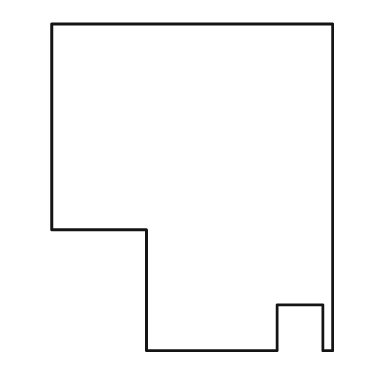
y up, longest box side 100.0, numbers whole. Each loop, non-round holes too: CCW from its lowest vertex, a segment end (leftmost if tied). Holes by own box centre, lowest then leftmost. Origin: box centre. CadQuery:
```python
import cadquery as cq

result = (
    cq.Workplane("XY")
    .moveTo(-14.0, -50.0)
    .lineTo(26.0, -50.0)
    .lineTo(26.0, -36.0)
    .lineTo(40.0, -36.0)
    .lineTo(40.0, -50.0)
    .lineTo(43.0, -50.0)
    .lineTo(43.0, 50.0)
    .lineTo(-43.0, 50.0)
    .lineTo(-43.0, -13.0)
    .lineTo(-14.0, -13.0)
    .close()
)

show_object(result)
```